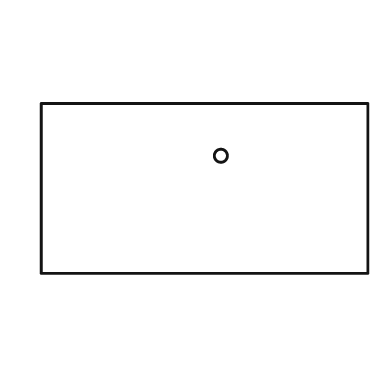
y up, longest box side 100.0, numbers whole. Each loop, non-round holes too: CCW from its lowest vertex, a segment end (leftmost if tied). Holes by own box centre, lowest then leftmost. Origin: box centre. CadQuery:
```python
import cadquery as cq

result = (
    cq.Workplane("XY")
    .moveTo(-50.0, -26.0)
    .lineTo(50.0, -26.0)
    .lineTo(50.0, 26.0)
    .lineTo(-50.0, 26.0)
    .close()
    .moveTo(5.0, 10.0)
    .circle(2.0)
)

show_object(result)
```